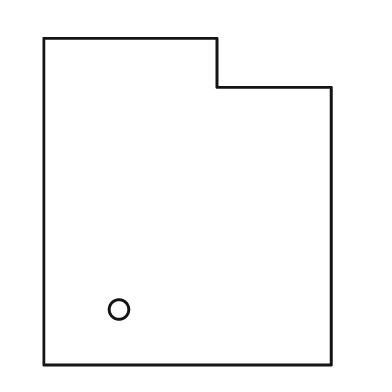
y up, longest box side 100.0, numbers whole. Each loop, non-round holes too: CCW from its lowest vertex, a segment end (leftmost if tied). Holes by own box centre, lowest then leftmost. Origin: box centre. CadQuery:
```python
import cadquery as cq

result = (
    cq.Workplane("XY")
    .moveTo(-44.0, -50.0)
    .lineTo(44.0, -50.0)
    .lineTo(44.0, 35.0)
    .lineTo(9.0, 35.0)
    .lineTo(9.0, 50.0)
    .lineTo(-44.0, 50.0)
    .close()
    .moveTo(-21.0, -33.0)
    .circle(3.0)
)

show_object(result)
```